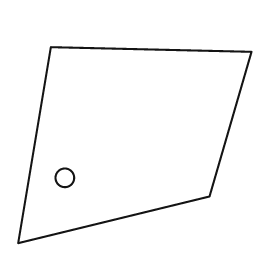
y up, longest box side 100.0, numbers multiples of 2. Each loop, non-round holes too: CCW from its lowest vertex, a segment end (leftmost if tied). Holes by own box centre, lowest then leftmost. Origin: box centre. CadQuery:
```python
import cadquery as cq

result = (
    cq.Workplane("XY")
    .moveTo(-50.0, -42.0)
    .lineTo(32.0, -22.0)
    .lineTo(50.0, 40.0)
    .lineTo(-36.0, 42.0)
    .close()
    .moveTo(-30.0, -14.0)
    .circle(4.0)
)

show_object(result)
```